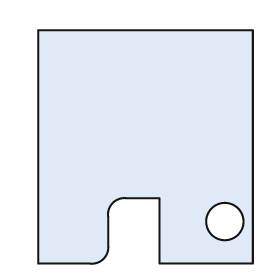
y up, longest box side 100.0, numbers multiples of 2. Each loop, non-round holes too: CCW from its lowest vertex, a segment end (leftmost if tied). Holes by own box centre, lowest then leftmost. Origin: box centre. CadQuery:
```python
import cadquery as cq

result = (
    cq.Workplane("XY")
    .moveTo(-46.0, -50.0)
    .lineTo(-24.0, -50.0)
    .threePointArc((-18.0, -48.0), (-16.0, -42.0))
    .lineTo(-16.0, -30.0)
    .threePointArc((-14.0, -24.0), (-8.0, -22.0))
    .lineTo(6.0, -22.0)
    .lineTo(6.0, -50.0)
    .lineTo(46.0, -50.0)
    .lineTo(46.0, 50.0)
    .lineTo(-46.0, 50.0)
    .close()
    .moveTo(34.0, -32.0)
    .circle(8.0)
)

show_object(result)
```